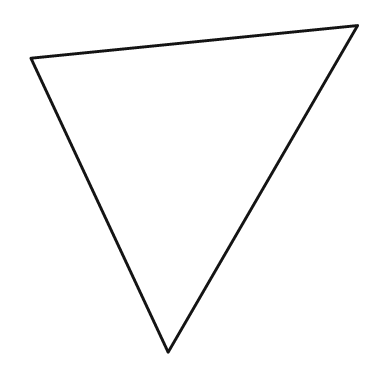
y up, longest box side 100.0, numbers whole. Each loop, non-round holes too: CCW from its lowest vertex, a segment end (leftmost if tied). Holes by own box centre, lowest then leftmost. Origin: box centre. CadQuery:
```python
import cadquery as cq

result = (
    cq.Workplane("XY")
    .moveTo(-8.0, -50.0)
    .lineTo(50.0, 50.0)
    .lineTo(-50.0, 40.0)
    .close()
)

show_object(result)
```